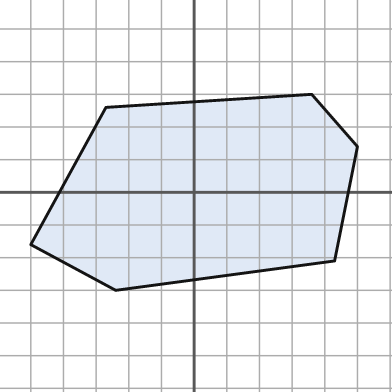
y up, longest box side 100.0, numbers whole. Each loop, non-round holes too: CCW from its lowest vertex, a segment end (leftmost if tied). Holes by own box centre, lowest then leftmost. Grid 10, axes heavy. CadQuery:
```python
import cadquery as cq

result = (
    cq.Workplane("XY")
    .moveTo(-24.0, -30.0)
    .lineTo(43.0, -21.0)
    .lineTo(50.0, 14.0)
    .lineTo(36.0, 30.0)
    .lineTo(-27.0, 26.0)
    .lineTo(-50.0, -16.0)
    .close()
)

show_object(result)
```